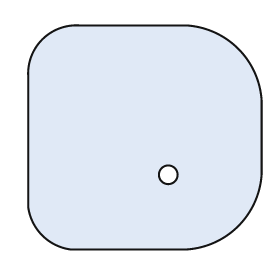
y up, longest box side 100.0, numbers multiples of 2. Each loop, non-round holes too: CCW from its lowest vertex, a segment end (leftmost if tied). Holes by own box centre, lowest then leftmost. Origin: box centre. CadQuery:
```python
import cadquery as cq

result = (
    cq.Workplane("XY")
    .moveTo(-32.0, -48.0)
    .lineTo(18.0, -48.0)
    .threePointArc((40.0, -38.0), (50.0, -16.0))
    .lineTo(50.0, 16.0)
    .threePointArc((40.0, 38.0), (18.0, 48.0))
    .lineTo(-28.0, 48.0)
    .threePointArc((-44.0, 42.0), (-50.0, 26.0))
    .lineTo(-50.0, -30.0)
    .threePointArc((-44.0, -42.0), (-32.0, -48.0))
    .close()
    .moveTo(10.0, -16.0)
    .circle(4.0)
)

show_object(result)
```